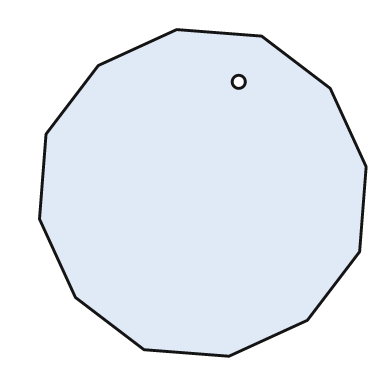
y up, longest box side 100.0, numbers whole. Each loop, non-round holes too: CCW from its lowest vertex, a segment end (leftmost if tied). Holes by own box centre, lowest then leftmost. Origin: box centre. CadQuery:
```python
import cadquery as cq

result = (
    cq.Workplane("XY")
    .moveTo(8.0, -50.0)
    .lineTo(32.0, -39.0)
    .lineTo(48.0, -18.0)
    .lineTo(50.0, 8.0)
    .lineTo(39.0, 32.0)
    .lineTo(18.0, 48.0)
    .lineTo(-8.0, 50.0)
    .lineTo(-32.0, 39.0)
    .lineTo(-48.0, 18.0)
    .lineTo(-50.0, -8.0)
    .lineTo(-39.0, -32.0)
    .lineTo(-18.0, -48.0)
    .close()
    .moveTo(11.0, 34.0)
    .circle(2.0)
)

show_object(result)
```